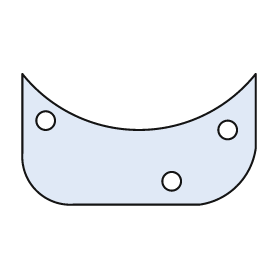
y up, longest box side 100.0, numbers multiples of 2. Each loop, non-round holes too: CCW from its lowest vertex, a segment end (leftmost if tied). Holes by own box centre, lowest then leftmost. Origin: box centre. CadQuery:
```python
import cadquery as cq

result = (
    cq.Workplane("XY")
    .moveTo(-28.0, -28.0)
    .lineTo(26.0, -28.0)
    .threePointArc((42.0, -20.0), (50.0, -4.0))
    .lineTo(50.0, 28.0)
    .threePointArc((0.0, 4.0), (-50.0, 28.0))
    .lineTo(-50.0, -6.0)
    .threePointArc((-44.0, -22.0), (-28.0, -28.0))
    .close()
    .moveTo(14.0, -18.0)
    .circle(4.0)
    .moveTo(38.0, 4.0)
    .circle(4.0)
    .moveTo(-40.0, 8.0)
    .circle(4.0)
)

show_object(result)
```